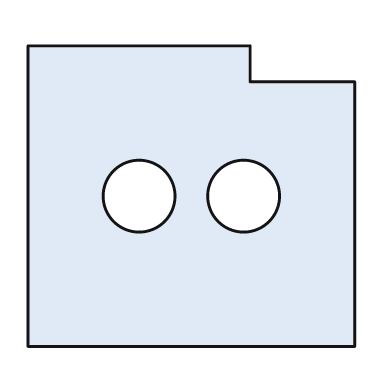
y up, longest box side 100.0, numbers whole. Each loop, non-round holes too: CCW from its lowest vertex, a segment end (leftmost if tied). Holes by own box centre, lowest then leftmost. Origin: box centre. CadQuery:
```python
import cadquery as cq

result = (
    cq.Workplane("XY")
    .moveTo(-50.0, -46.0)
    .lineTo(50.0, -46.0)
    .lineTo(50.0, 35.0)
    .lineTo(18.0, 35.0)
    .lineTo(18.0, 46.0)
    .lineTo(-50.0, 46.0)
    .close()
    .moveTo(-16.0, 0.0)
    .circle(11.0)
    .moveTo(16.0, 0.0)
    .circle(11.0)
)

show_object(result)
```